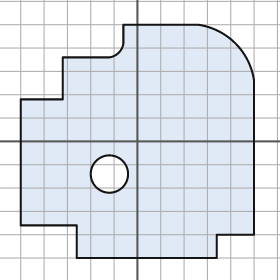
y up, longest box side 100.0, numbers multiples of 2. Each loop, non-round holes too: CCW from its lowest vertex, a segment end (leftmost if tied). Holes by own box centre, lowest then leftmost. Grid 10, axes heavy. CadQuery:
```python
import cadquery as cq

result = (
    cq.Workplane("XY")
    .moveTo(-26.0, -50.0)
    .lineTo(34.0, -50.0)
    .lineTo(34.0, -40.0)
    .lineTo(50.0, -40.0)
    .lineTo(50.0, 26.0)
    .threePointArc((42.0, 42.0), (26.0, 50.0))
    .lineTo(-6.0, 50.0)
    .lineTo(-6.0, 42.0)
    .threePointArc((-8.0, 38.0), (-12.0, 36.0))
    .lineTo(-32.0, 36.0)
    .lineTo(-32.0, 18.0)
    .lineTo(-50.0, 18.0)
    .lineTo(-50.0, -36.0)
    .lineTo(-26.0, -36.0)
    .close()
    .moveTo(-12.0, -14.0)
    .circle(8.0)
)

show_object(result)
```